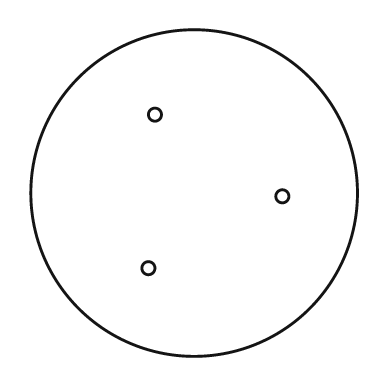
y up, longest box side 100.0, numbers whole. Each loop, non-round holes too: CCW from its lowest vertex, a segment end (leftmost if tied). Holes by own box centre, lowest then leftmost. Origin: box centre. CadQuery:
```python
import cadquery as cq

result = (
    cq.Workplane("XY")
    .moveTo(0.0, 0.0)
    .circle(50.0)
    .moveTo(-14.0, -23.0)
    .circle(2.0)
    .moveTo(27.0, -1.0)
    .circle(2.0)
    .moveTo(-12.0, 24.0)
    .circle(2.0)
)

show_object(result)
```